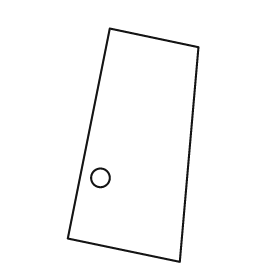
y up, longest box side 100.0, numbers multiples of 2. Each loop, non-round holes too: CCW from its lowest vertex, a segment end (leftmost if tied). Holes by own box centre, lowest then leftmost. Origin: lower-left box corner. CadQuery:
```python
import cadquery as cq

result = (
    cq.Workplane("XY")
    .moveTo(48.0, 0.0)
    .lineTo(56.0, 92.0)
    .lineTo(18.0, 100.0)
    .lineTo(0.0, 10.0)
    .close()
    .moveTo(14.0, 36.0)
    .circle(4.0)
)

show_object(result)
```